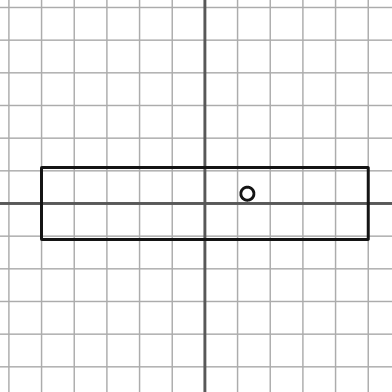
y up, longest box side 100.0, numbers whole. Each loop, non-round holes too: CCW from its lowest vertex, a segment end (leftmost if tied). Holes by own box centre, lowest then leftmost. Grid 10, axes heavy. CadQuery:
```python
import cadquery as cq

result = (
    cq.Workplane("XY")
    .moveTo(-50.0, -11.0)
    .lineTo(50.0, -11.0)
    .lineTo(50.0, 11.0)
    .lineTo(-50.0, 11.0)
    .close()
    .moveTo(13.0, 3.0)
    .circle(2.0)
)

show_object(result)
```